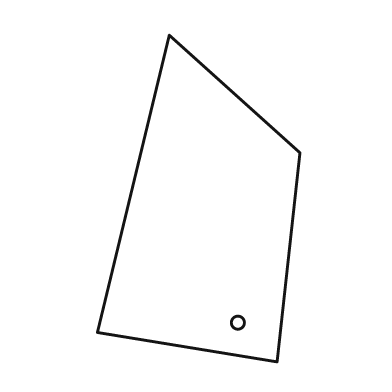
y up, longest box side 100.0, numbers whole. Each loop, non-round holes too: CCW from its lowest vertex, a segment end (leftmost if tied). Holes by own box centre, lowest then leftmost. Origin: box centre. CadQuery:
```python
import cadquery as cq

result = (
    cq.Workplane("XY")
    .moveTo(24.0, -50.0)
    .lineTo(31.0, 14.0)
    .lineTo(-9.0, 50.0)
    .lineTo(-31.0, -41.0)
    .close()
    .moveTo(12.0, -38.0)
    .circle(2.0)
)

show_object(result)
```